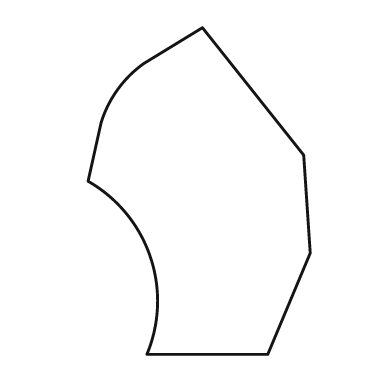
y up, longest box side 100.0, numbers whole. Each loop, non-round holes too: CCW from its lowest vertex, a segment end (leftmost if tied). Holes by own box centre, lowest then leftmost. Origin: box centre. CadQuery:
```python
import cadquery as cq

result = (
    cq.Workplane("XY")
    .moveTo(-16.0, -50.0)
    .lineTo(21.0, -50.0)
    .lineTo(34.0, -19.0)
    .lineTo(32.0, 11.0)
    .lineTo(1.0, 50.0)
    .lineTo(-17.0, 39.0)
    .threePointArc((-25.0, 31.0), (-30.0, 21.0))
    .lineTo(-34.0, 3.0)
    .threePointArc((-15.0, -20.0), (-16.0, -50.0))
    .close()
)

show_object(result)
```